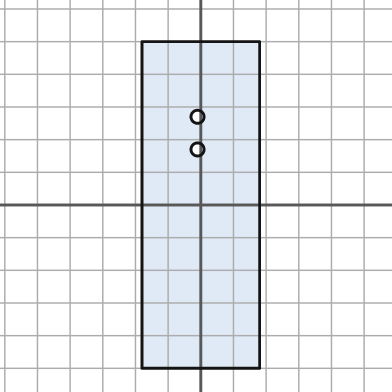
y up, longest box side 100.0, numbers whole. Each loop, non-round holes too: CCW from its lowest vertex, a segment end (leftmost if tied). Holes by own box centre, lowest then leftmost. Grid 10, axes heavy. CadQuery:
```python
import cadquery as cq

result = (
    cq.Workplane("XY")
    .moveTo(-18.0, -50.0)
    .lineTo(18.0, -50.0)
    .lineTo(18.0, 50.0)
    .lineTo(-18.0, 50.0)
    .close()
    .moveTo(-1.0, 17.0)
    .circle(2.0)
    .moveTo(-1.0, 27.0)
    .circle(2.0)
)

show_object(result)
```